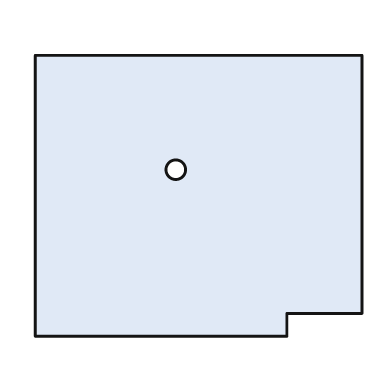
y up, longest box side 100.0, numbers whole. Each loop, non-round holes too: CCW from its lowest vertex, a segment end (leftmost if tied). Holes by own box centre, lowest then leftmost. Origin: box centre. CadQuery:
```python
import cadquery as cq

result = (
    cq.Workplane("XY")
    .moveTo(-50.0, -43.0)
    .lineTo(27.0, -43.0)
    .lineTo(27.0, -36.0)
    .lineTo(50.0, -36.0)
    .lineTo(50.0, 43.0)
    .lineTo(-50.0, 43.0)
    .close()
    .moveTo(-7.0, 8.0)
    .circle(3.0)
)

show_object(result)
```